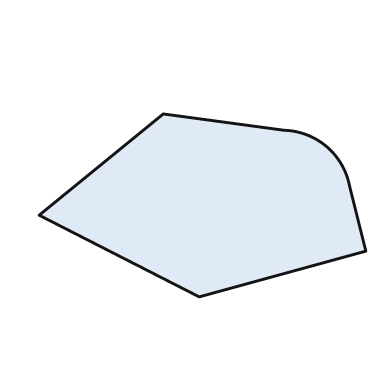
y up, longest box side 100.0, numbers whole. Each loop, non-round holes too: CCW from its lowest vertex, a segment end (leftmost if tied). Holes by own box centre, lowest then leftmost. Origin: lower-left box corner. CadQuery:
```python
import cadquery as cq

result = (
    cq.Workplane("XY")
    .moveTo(49.0, 0.0)
    .lineTo(100.0, 14.0)
    .lineTo(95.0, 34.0)
    .threePointArc((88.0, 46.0), (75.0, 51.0))
    .lineTo(38.0, 56.0)
    .lineTo(0.0, 25.0)
    .close()
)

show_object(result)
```